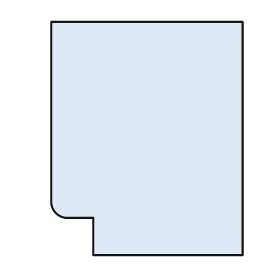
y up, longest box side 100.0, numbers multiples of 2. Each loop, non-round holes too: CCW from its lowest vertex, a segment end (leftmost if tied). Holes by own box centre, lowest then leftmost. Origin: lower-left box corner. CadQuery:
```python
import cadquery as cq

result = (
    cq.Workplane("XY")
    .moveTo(18.0, 0.0)
    .lineTo(82.0, 0.0)
    .lineTo(82.0, 100.0)
    .lineTo(0.0, 100.0)
    .lineTo(0.0, 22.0)
    .threePointArc((2.0, 18.0), (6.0, 16.0))
    .lineTo(18.0, 16.0)
    .close()
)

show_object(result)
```